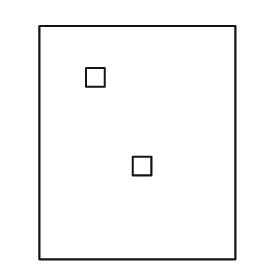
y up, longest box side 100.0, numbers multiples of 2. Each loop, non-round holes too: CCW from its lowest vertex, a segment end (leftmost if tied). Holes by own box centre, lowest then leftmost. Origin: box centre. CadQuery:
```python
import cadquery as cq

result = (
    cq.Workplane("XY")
    .moveTo(-42.0, -50.0)
    .lineTo(42.0, -50.0)
    .lineTo(42.0, 50.0)
    .lineTo(-42.0, 50.0)
    .close()
    .moveTo(-2.0, -14.0)
    .lineTo(6.0, -14.0)
    .lineTo(6.0, -6.0)
    .lineTo(-2.0, -6.0)
    .close()
    .moveTo(-22.0, 24.0)
    .lineTo(-14.0, 24.0)
    .lineTo(-14.0, 32.0)
    .lineTo(-22.0, 32.0)
    .close()
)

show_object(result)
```